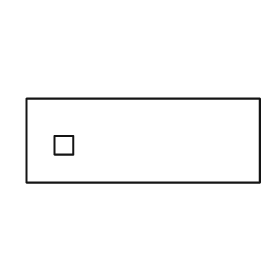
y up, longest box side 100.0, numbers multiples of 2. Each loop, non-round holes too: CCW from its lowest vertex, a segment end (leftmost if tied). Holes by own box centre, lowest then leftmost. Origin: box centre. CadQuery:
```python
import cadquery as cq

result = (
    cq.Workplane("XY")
    .moveTo(-50.0, -18.0)
    .lineTo(50.0, -18.0)
    .lineTo(50.0, 18.0)
    .lineTo(-50.0, 18.0)
    .close()
    .moveTo(-38.0, -6.0)
    .lineTo(-30.0, -6.0)
    .lineTo(-30.0, 2.0)
    .lineTo(-38.0, 2.0)
    .close()
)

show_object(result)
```